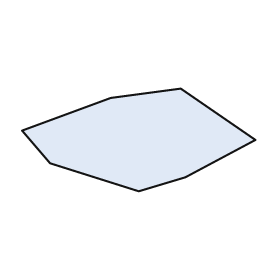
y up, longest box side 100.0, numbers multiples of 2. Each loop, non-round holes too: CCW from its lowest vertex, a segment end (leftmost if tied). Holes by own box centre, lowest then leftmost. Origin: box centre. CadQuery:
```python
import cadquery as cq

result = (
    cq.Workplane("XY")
    .moveTo(0.0, -22.0)
    .lineTo(20.0, -16.0)
    .lineTo(50.0, 0.0)
    .lineTo(18.0, 22.0)
    .lineTo(-12.0, 18.0)
    .lineTo(-50.0, 4.0)
    .lineTo(-38.0, -10.0)
    .close()
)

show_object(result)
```